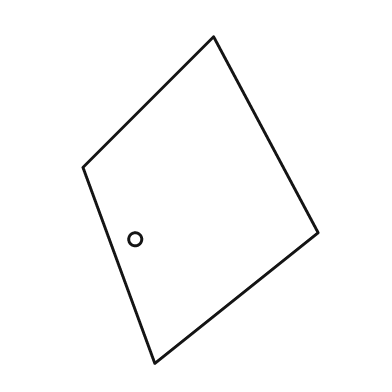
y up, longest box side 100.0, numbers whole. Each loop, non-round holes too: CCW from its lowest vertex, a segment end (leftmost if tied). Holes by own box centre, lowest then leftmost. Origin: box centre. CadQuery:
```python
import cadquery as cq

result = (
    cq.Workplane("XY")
    .moveTo(-14.0, -50.0)
    .lineTo(36.0, -10.0)
    .lineTo(4.0, 50.0)
    .lineTo(-36.0, 10.0)
    .close()
    .moveTo(-20.0, -12.0)
    .circle(2.0)
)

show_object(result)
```